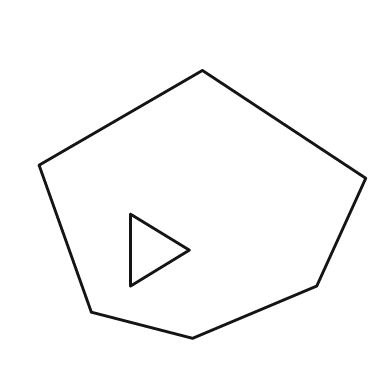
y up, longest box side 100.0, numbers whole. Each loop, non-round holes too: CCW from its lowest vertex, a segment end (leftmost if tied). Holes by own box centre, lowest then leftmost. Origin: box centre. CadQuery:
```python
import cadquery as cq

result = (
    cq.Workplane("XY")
    .moveTo(-3.0, -41.0)
    .lineTo(35.0, -25.0)
    .lineTo(50.0, 8.0)
    .lineTo(0.0, 41.0)
    .lineTo(-50.0, 12.0)
    .lineTo(-34.0, -33.0)
    .close()
    .moveTo(-22.0, -25.0)
    .lineTo(-4.0, -14.0)
    .lineTo(-22.0, -3.0)
    .close()
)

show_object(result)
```